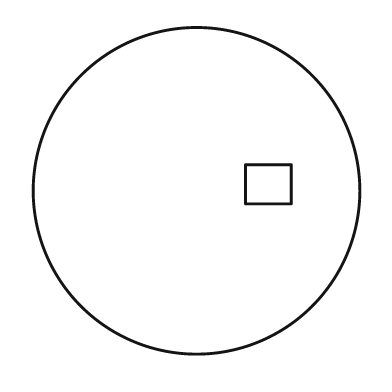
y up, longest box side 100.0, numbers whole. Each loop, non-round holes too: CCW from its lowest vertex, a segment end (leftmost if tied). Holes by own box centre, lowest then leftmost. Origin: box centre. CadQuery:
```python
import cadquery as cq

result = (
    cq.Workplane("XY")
    .moveTo(0.0, 0.0)
    .circle(50.0)
    .moveTo(15.0, -4.0)
    .lineTo(29.0, -4.0)
    .lineTo(29.0, 8.0)
    .lineTo(15.0, 8.0)
    .close()
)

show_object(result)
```